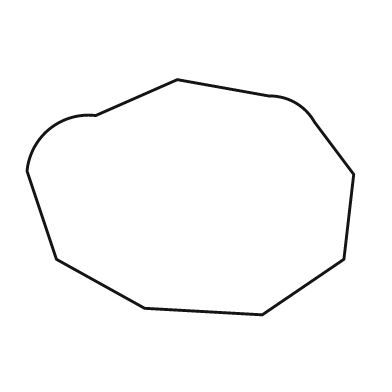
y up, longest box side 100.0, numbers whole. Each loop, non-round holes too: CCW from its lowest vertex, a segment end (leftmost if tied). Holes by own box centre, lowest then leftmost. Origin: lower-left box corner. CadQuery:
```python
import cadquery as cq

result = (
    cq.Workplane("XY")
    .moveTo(72.0, 0.0)
    .lineTo(97.0, 17.0)
    .lineTo(100.0, 43.0)
    .lineTo(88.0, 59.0)
    .threePointArc((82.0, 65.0), (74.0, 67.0))
    .lineTo(46.0, 72.0)
    .lineTo(21.0, 61.0)
    .threePointArc((7.0, 57.0), (0.0, 44.0))
    .lineTo(9.0, 17.0)
    .lineTo(36.0, 2.0)
    .close()
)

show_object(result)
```